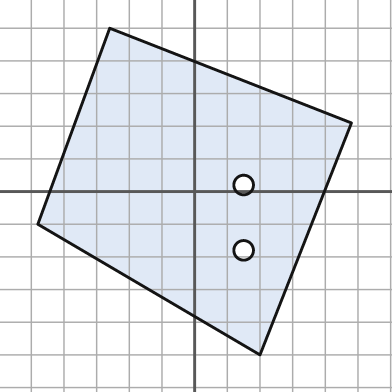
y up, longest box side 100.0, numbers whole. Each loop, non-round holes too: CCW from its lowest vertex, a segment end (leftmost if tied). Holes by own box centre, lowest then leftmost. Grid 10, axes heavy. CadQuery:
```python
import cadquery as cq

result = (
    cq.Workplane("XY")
    .moveTo(20.0, -50.0)
    .lineTo(48.0, 21.0)
    .lineTo(-26.0, 50.0)
    .lineTo(-48.0, -10.0)
    .close()
    .moveTo(15.0, -18.0)
    .circle(3.0)
    .moveTo(15.0, 2.0)
    .circle(3.0)
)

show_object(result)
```